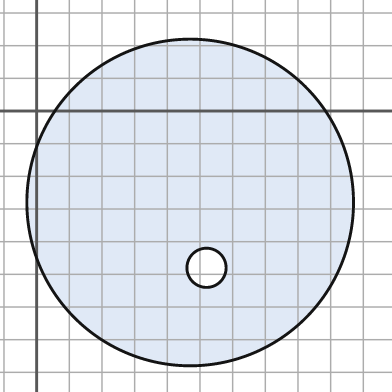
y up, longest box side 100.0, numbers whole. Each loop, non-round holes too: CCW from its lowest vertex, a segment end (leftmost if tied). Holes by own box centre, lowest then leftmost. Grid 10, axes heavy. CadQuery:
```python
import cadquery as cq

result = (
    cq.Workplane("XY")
    .moveTo(47.0, -28.0)
    .circle(50.0)
    .moveTo(52.0, -48.0)
    .circle(6.0)
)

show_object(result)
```